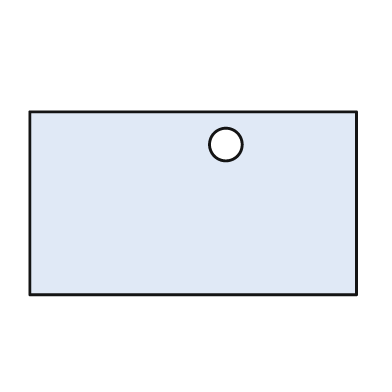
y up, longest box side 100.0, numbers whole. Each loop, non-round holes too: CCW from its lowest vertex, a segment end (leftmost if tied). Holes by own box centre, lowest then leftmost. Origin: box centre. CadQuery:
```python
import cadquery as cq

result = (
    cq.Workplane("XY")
    .moveTo(-50.0, -28.0)
    .lineTo(50.0, -28.0)
    .lineTo(50.0, 28.0)
    .lineTo(-50.0, 28.0)
    .close()
    .moveTo(10.0, 18.0)
    .circle(5.0)
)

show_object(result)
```